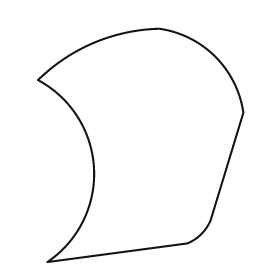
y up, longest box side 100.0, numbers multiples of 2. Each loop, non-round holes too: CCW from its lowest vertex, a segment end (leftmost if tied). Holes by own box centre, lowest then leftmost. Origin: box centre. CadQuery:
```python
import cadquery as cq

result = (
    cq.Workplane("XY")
    .moveTo(-40.0, -50.0)
    .lineTo(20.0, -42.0)
    .threePointArc((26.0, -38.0), (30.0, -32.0))
    .lineTo(44.0, 14.0)
    .threePointArc((32.0, 38.0), (8.0, 50.0))
    .threePointArc((-20.0, 44.0), (-44.0, 28.0))
    .threePointArc((-20.0, -10.0), (-40.0, -50.0))
    .close()
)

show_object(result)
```